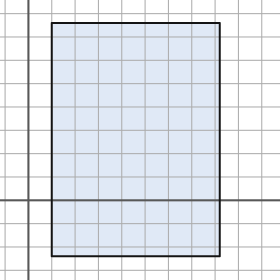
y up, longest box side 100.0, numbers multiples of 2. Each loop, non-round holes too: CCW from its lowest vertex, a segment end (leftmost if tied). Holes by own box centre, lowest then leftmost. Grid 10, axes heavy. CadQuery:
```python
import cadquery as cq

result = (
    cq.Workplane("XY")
    .moveTo(10.0, -24.0)
    .lineTo(82.0, -24.0)
    .lineTo(82.0, 76.0)
    .lineTo(10.0, 76.0)
    .close()
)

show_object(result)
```